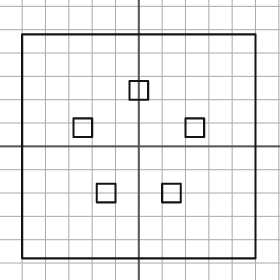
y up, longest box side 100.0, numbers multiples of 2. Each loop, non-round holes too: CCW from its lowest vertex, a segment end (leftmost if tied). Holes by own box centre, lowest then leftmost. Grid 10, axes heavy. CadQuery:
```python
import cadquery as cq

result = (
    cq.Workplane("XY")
    .moveTo(-50.0, -48.0)
    .lineTo(50.0, -48.0)
    .lineTo(50.0, 48.0)
    .lineTo(-50.0, 48.0)
    .close()
    .moveTo(-18.0, -24.0)
    .lineTo(-10.0, -24.0)
    .lineTo(-10.0, -16.0)
    .lineTo(-18.0, -16.0)
    .close()
    .moveTo(10.0, -24.0)
    .lineTo(18.0, -24.0)
    .lineTo(18.0, -16.0)
    .lineTo(10.0, -16.0)
    .close()
    .moveTo(-28.0, 4.0)
    .lineTo(-20.0, 4.0)
    .lineTo(-20.0, 12.0)
    .lineTo(-28.0, 12.0)
    .close()
    .moveTo(20.0, 4.0)
    .lineTo(28.0, 4.0)
    .lineTo(28.0, 12.0)
    .lineTo(20.0, 12.0)
    .close()
    .moveTo(-4.0, 20.0)
    .lineTo(4.0, 20.0)
    .lineTo(4.0, 28.0)
    .lineTo(-4.0, 28.0)
    .close()
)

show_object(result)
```